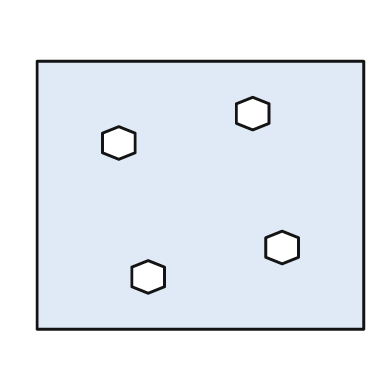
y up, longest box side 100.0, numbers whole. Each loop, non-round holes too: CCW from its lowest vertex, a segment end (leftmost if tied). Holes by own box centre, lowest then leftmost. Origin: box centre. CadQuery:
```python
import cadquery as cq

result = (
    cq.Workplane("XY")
    .moveTo(-50.0, -41.0)
    .lineTo(50.0, -41.0)
    .lineTo(50.0, 41.0)
    .lineTo(-50.0, 41.0)
    .close()
    .moveTo(-16.0, -30.0)
    .lineTo(-11.0, -28.0)
    .lineTo(-11.0, -22.0)
    .lineTo(-16.0, -20.0)
    .lineTo(-21.0, -22.0)
    .lineTo(-21.0, -28.0)
    .close()
    .moveTo(25.0, -21.0)
    .lineTo(30.0, -19.0)
    .lineTo(30.0, -13.0)
    .lineTo(25.0, -11.0)
    .lineTo(20.0, -13.0)
    .lineTo(20.0, -19.0)
    .close()
    .moveTo(-25.0, 11.0)
    .lineTo(-20.0, 13.0)
    .lineTo(-20.0, 19.0)
    .lineTo(-25.0, 21.0)
    .lineTo(-30.0, 19.0)
    .lineTo(-30.0, 13.0)
    .close()
    .moveTo(16.0, 20.0)
    .lineTo(21.0, 22.0)
    .lineTo(21.0, 28.0)
    .lineTo(16.0, 30.0)
    .lineTo(11.0, 28.0)
    .lineTo(11.0, 22.0)
    .close()
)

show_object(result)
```